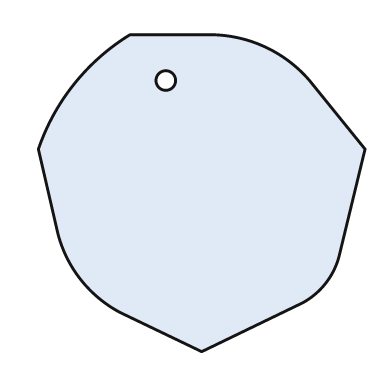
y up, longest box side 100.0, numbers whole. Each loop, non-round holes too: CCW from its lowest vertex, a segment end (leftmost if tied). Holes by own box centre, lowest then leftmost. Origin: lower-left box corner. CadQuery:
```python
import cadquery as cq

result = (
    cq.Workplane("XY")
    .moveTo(50.0, 0.0)
    .lineTo(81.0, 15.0)
    .threePointArc((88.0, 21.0), (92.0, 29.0))
    .lineTo(100.0, 62.0)
    .lineTo(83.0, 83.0)
    .threePointArc((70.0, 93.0), (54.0, 97.0))
    .lineTo(28.0, 97.0)
    .threePointArc((11.0, 82.0), (0.0, 62.0))
    .lineTo(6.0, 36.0)
    .threePointArc((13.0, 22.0), (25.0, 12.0))
    .close()
    .moveTo(39.0, 83.0)
    .circle(3.0)
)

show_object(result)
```